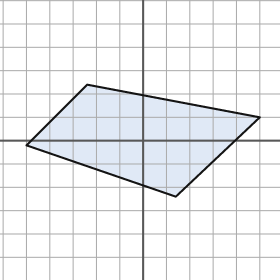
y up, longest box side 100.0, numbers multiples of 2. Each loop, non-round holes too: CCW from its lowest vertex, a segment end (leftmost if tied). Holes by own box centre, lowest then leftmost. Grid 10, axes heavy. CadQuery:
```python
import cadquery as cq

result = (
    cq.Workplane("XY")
    .moveTo(14.0, -24.0)
    .lineTo(50.0, 10.0)
    .lineTo(-24.0, 24.0)
    .lineTo(-50.0, -2.0)
    .close()
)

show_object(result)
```